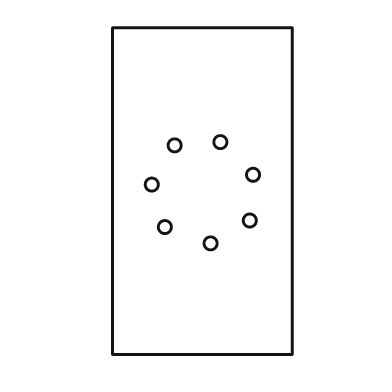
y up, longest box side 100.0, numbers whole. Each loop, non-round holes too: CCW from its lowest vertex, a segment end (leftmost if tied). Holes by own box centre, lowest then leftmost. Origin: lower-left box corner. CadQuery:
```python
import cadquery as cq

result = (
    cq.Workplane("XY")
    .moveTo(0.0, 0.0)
    .lineTo(55.0, 0.0)
    .lineTo(55.0, 100.0)
    .lineTo(0.0, 100.0)
    .close()
    .moveTo(30.0, 34.0)
    .circle(2.0)
    .moveTo(16.0, 39.0)
    .circle(2.0)
    .moveTo(42.0, 41.0)
    .circle(2.0)
    .moveTo(12.0, 52.0)
    .circle(2.0)
    .moveTo(43.0, 55.0)
    .circle(2.0)
    .moveTo(19.0, 64.0)
    .circle(2.0)
    .moveTo(33.0, 65.0)
    .circle(2.0)
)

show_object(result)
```